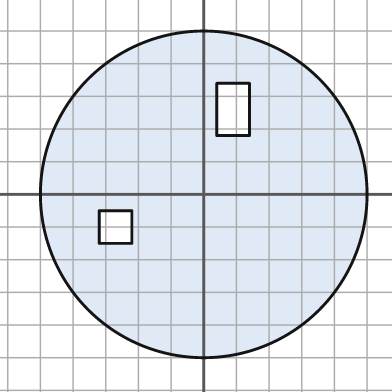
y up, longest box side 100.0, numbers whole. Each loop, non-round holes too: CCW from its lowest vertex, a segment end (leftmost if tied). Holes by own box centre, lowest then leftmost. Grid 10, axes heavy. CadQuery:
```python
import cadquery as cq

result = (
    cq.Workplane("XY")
    .moveTo(0.0, 0.0)
    .circle(50.0)
    .moveTo(-32.0, -15.0)
    .lineTo(-22.0, -15.0)
    .lineTo(-22.0, -5.0)
    .lineTo(-32.0, -5.0)
    .close()
    .moveTo(4.0, 18.0)
    .lineTo(14.0, 18.0)
    .lineTo(14.0, 34.0)
    .lineTo(4.0, 34.0)
    .close()
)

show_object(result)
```